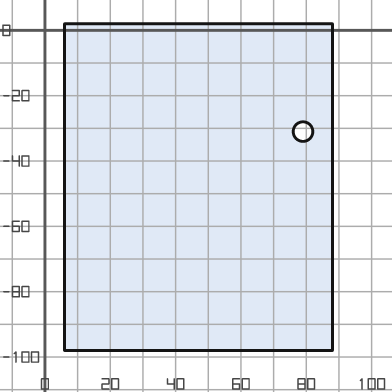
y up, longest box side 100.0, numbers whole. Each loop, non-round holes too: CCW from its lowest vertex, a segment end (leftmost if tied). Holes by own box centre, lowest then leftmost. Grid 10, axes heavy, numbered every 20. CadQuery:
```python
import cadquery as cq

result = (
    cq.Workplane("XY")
    .moveTo(6.0, -98.0)
    .lineTo(88.0, -98.0)
    .lineTo(88.0, 2.0)
    .lineTo(6.0, 2.0)
    .close()
    .moveTo(79.0, -31.0)
    .circle(3.0)
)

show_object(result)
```